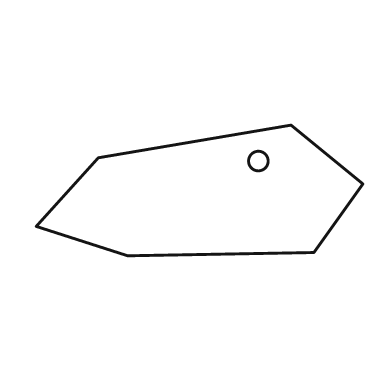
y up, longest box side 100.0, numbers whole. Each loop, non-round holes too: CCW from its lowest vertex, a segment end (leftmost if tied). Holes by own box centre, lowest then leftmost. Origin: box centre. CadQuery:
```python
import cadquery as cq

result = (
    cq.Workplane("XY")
    .moveTo(-22.0, -20.0)
    .lineTo(35.0, -19.0)
    .lineTo(50.0, 2.0)
    .lineTo(28.0, 20.0)
    .lineTo(-31.0, 10.0)
    .lineTo(-50.0, -11.0)
    .close()
    .moveTo(18.0, 9.0)
    .circle(3.0)
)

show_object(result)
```